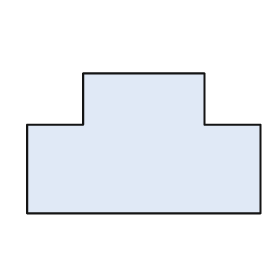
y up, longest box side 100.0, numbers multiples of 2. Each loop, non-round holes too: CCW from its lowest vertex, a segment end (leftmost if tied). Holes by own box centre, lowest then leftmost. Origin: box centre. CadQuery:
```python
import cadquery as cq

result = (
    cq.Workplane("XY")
    .moveTo(-50.0, -30.0)
    .lineTo(50.0, -30.0)
    .lineTo(50.0, 8.0)
    .lineTo(26.0, 8.0)
    .lineTo(26.0, 30.0)
    .lineTo(-26.0, 30.0)
    .lineTo(-26.0, 8.0)
    .lineTo(-50.0, 8.0)
    .close()
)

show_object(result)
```